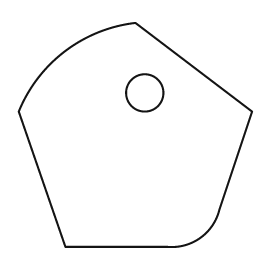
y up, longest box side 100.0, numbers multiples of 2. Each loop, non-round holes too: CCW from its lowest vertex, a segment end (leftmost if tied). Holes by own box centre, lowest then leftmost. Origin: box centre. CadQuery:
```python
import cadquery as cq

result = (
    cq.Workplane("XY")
    .moveTo(-30.0, -48.0)
    .lineTo(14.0, -48.0)
    .threePointArc((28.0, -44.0), (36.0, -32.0))
    .lineTo(50.0, 10.0)
    .lineTo(0.0, 48.0)
    .threePointArc((-30.0, 36.0), (-50.0, 10.0))
    .close()
    .moveTo(4.0, 18.0)
    .circle(8.0)
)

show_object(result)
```